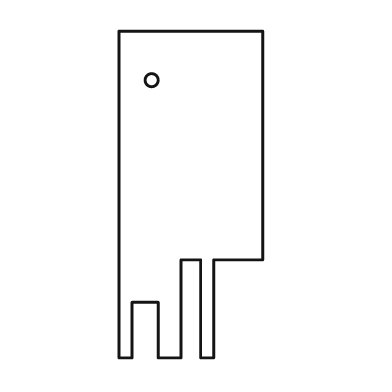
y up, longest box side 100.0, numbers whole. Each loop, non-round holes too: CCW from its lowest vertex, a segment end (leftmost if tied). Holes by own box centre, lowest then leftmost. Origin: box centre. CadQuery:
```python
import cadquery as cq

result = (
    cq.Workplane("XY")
    .moveTo(-22.0, -50.0)
    .lineTo(-18.0, -50.0)
    .lineTo(-18.0, -33.0)
    .lineTo(-10.0, -33.0)
    .lineTo(-10.0, -50.0)
    .lineTo(-3.0, -50.0)
    .lineTo(-3.0, -20.0)
    .lineTo(3.0, -20.0)
    .lineTo(3.0, -50.0)
    .lineTo(7.0, -50.0)
    .lineTo(7.0, -20.0)
    .lineTo(22.0, -20.0)
    .lineTo(22.0, 50.0)
    .lineTo(-22.0, 50.0)
    .close()
    .moveTo(-12.0, 35.0)
    .circle(2.0)
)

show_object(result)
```